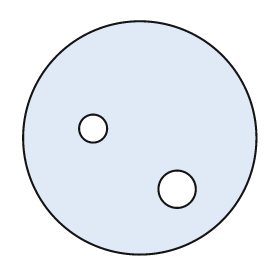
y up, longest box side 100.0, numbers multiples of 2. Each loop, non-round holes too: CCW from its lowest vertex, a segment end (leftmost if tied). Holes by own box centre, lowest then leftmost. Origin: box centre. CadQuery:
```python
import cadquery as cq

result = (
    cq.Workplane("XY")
    .moveTo(0.0, 0.0)
    .circle(50.0)
    .moveTo(16.0, -22.0)
    .circle(8.0)
    .moveTo(-20.0, 4.0)
    .circle(6.0)
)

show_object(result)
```